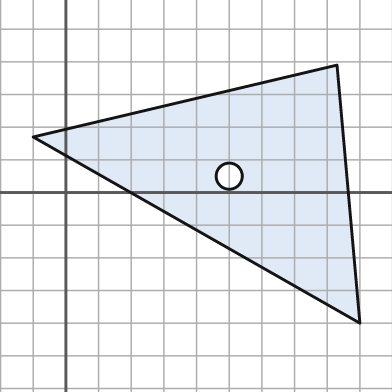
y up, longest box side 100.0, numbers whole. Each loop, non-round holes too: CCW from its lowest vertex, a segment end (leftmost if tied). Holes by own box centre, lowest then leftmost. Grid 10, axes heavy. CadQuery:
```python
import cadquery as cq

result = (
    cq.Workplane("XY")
    .moveTo(90.0, -40.0)
    .lineTo(83.0, 39.0)
    .lineTo(-10.0, 17.0)
    .close()
    .moveTo(50.0, 5.0)
    .circle(4.0)
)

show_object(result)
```